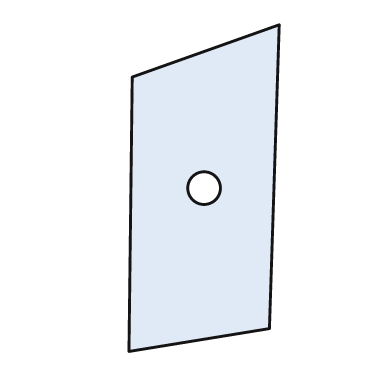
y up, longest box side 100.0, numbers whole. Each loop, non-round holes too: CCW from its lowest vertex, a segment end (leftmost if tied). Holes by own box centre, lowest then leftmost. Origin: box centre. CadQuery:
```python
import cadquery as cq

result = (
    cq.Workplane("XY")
    .moveTo(-23.0, -50.0)
    .lineTo(20.0, -43.0)
    .lineTo(23.0, 50.0)
    .lineTo(-22.0, 34.0)
    .close()
    .moveTo(0.0, 0.0)
    .circle(5.0)
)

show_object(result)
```